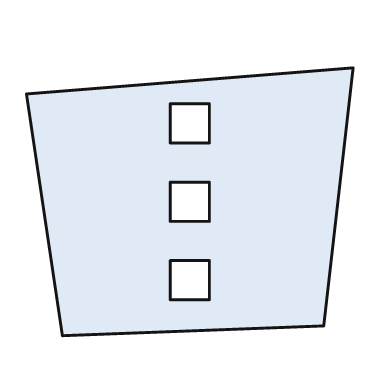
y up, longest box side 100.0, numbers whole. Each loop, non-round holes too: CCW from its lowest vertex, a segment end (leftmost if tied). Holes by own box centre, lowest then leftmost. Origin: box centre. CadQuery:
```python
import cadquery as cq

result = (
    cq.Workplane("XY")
    .moveTo(-39.0, -41.0)
    .lineTo(41.0, -38.0)
    .lineTo(50.0, 41.0)
    .lineTo(-50.0, 33.0)
    .close()
    .moveTo(-6.0, -30.0)
    .lineTo(6.0, -30.0)
    .lineTo(6.0, -18.0)
    .lineTo(-6.0, -18.0)
    .close()
    .moveTo(-6.0, -6.0)
    .lineTo(6.0, -6.0)
    .lineTo(6.0, 6.0)
    .lineTo(-6.0, 6.0)
    .close()
    .moveTo(-6.0, 18.0)
    .lineTo(6.0, 18.0)
    .lineTo(6.0, 30.0)
    .lineTo(-6.0, 30.0)
    .close()
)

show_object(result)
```